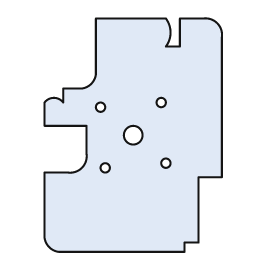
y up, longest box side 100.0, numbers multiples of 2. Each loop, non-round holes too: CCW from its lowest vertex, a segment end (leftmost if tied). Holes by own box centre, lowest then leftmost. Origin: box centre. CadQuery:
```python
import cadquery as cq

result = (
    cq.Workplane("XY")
    .moveTo(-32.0, -50.0)
    .lineTo(22.0, -50.0)
    .lineTo(22.0, -46.0)
    .lineTo(28.0, -46.0)
    .lineTo(28.0, -18.0)
    .lineTo(38.0, -18.0)
    .lineTo(38.0, 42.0)
    .threePointArc((36.0, 48.0), (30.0, 50.0))
    .lineTo(20.0, 50.0)
    .lineTo(20.0, 38.0)
    .lineTo(14.0, 38.0)
    .threePointArc((16.0, 44.0), (14.0, 50.0))
    .lineTo(-16.0, 50.0)
    .lineTo(-16.0, 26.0)
    .threePointArc((-18.0, 22.0), (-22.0, 20.0))
    .lineTo(-30.0, 20.0)
    .lineTo(-30.0, 14.0)
    .threePointArc((-34.0, 16.0), (-38.0, 14.0))
    .lineTo(-38.0, 4.0)
    .lineTo(-20.0, 4.0)
    .lineTo(-20.0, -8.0)
    .threePointArc((-22.0, -14.0), (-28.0, -16.0))
    .lineTo(-38.0, -16.0)
    .lineTo(-38.0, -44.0)
    .threePointArc((-36.0, -48.0), (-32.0, -50.0))
    .close()
    .moveTo(-12.0, -14.0)
    .circle(2.0)
    .moveTo(14.0, -12.0)
    .circle(2.0)
    .moveTo(0.0, 0.0)
    .circle(4.0)
    .moveTo(-14.0, 12.0)
    .circle(2.0)
    .moveTo(12.0, 14.0)
    .circle(2.0)
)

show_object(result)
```